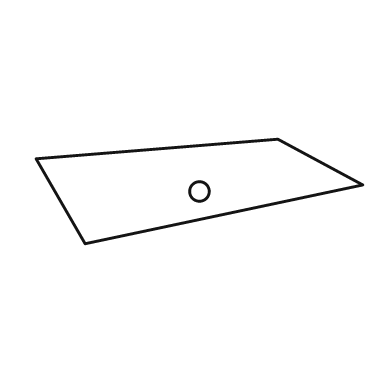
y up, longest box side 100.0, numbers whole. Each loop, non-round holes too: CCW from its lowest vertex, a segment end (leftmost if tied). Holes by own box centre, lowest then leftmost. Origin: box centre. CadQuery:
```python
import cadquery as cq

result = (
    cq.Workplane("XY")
    .moveTo(-35.0, -16.0)
    .lineTo(50.0, 2.0)
    .lineTo(24.0, 16.0)
    .lineTo(-50.0, 10.0)
    .close()
    .moveTo(0.0, 0.0)
    .circle(3.0)
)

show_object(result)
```